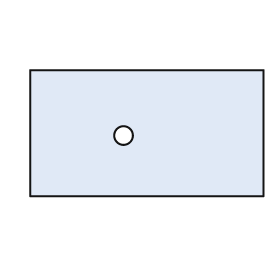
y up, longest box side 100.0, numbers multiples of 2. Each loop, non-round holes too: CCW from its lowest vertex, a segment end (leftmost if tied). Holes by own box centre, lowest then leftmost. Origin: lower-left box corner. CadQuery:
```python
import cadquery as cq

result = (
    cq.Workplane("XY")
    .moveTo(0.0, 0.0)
    .lineTo(100.0, 0.0)
    .lineTo(100.0, 54.0)
    .lineTo(0.0, 54.0)
    .close()
    .moveTo(40.0, 26.0)
    .circle(4.0)
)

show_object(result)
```